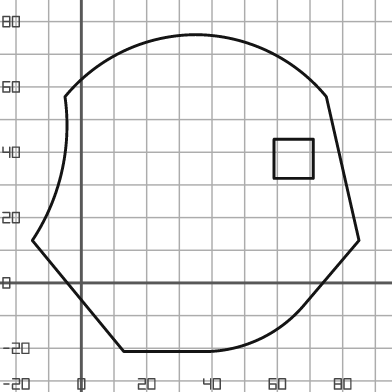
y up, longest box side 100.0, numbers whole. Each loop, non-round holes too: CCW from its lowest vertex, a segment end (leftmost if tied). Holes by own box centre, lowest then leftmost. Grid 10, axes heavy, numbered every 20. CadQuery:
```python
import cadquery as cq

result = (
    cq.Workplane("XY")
    .moveTo(13.0, -21.0)
    .lineTo(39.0, -21.0)
    .threePointArc((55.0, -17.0), (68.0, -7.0))
    .lineTo(85.0, 13.0)
    .lineTo(75.0, 57.0)
    .threePointArc((57.0, 71.0), (35.0, 76.0))
    .threePointArc((13.0, 71.0), (-5.0, 57.0))
    .threePointArc((-6.0, 34.0), (-15.0, 13.0))
    .close()
    .moveTo(59.0, 32.0)
    .lineTo(71.0, 32.0)
    .lineTo(71.0, 44.0)
    .lineTo(59.0, 44.0)
    .close()
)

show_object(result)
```